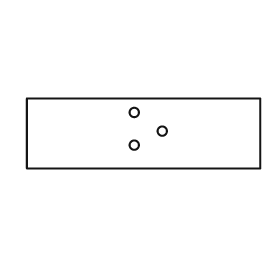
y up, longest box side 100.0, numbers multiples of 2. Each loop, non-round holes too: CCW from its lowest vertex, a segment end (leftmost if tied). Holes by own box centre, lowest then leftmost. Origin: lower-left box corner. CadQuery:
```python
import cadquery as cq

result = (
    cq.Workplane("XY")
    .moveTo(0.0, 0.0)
    .lineTo(100.0, 0.0)
    .lineTo(100.0, 30.0)
    .lineTo(0.0, 30.0)
    .close()
    .moveTo(46.0, 10.0)
    .circle(2.0)
    .moveTo(58.0, 16.0)
    .circle(2.0)
    .moveTo(46.0, 24.0)
    .circle(2.0)
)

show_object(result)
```